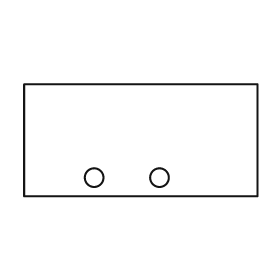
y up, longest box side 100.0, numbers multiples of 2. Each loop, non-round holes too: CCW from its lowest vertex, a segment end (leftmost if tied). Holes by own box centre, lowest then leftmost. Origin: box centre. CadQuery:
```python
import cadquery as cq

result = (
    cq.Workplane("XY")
    .moveTo(-50.0, -24.0)
    .lineTo(50.0, -24.0)
    .lineTo(50.0, 24.0)
    .lineTo(-50.0, 24.0)
    .close()
    .moveTo(-20.0, -16.0)
    .circle(4.0)
    .moveTo(8.0, -16.0)
    .circle(4.0)
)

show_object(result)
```